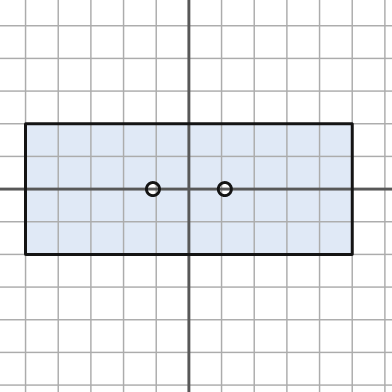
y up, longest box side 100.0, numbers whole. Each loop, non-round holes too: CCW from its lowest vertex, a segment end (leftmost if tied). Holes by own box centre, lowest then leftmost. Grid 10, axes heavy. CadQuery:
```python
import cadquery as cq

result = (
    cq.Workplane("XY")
    .moveTo(-50.0, -20.0)
    .lineTo(50.0, -20.0)
    .lineTo(50.0, 20.0)
    .lineTo(-50.0, 20.0)
    .close()
    .moveTo(-11.0, 0.0)
    .circle(2.0)
    .moveTo(11.0, 0.0)
    .circle(2.0)
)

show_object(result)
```